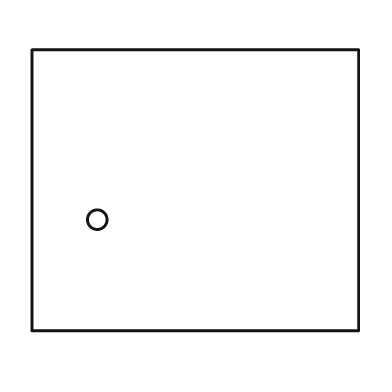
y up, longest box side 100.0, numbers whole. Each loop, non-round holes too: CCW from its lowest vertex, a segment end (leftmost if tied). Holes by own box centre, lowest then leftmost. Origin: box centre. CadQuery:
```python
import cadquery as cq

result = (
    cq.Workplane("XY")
    .moveTo(-50.0, -43.0)
    .lineTo(50.0, -43.0)
    .lineTo(50.0, 43.0)
    .lineTo(-50.0, 43.0)
    .close()
    .moveTo(-30.0, -9.0)
    .circle(3.0)
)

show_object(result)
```